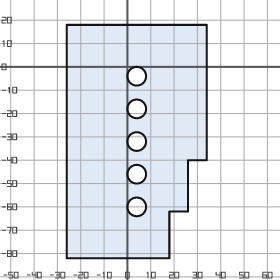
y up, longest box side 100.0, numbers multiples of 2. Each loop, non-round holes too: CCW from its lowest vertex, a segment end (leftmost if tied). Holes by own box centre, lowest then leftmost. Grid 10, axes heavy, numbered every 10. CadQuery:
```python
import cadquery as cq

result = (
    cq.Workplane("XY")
    .moveTo(-26.0, -82.0)
    .lineTo(18.0, -82.0)
    .lineTo(18.0, -62.0)
    .lineTo(26.0, -62.0)
    .lineTo(26.0, -40.0)
    .lineTo(34.0, -40.0)
    .lineTo(34.0, 18.0)
    .lineTo(-26.0, 18.0)
    .close()
    .moveTo(4.0, -60.0)
    .circle(4.0)
    .moveTo(4.0, -46.0)
    .circle(4.0)
    .moveTo(4.0, -32.0)
    .circle(4.0)
    .moveTo(4.0, -18.0)
    .circle(4.0)
    .moveTo(4.0, -4.0)
    .circle(4.0)
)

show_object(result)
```